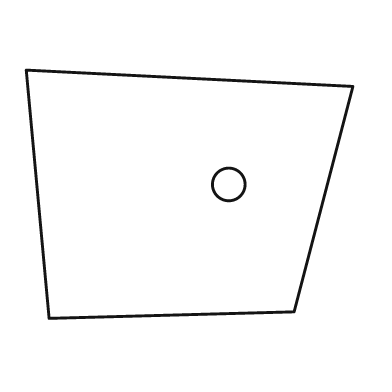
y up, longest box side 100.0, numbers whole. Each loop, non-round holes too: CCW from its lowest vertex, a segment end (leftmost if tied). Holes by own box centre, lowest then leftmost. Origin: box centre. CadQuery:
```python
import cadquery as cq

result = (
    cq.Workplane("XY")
    .moveTo(-43.0, -38.0)
    .lineTo(32.0, -36.0)
    .lineTo(50.0, 33.0)
    .lineTo(-50.0, 38.0)
    .close()
    .moveTo(12.0, 3.0)
    .circle(5.0)
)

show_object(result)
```